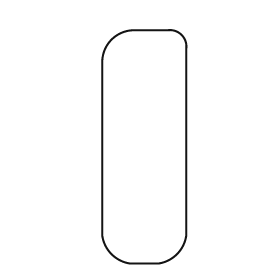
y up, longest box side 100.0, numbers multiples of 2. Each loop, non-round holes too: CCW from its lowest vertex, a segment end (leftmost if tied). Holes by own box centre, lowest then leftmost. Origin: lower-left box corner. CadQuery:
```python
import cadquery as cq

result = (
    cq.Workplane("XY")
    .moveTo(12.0, 0.0)
    .lineTo(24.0, 0.0)
    .threePointArc((32.0, 4.0), (36.0, 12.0))
    .lineTo(36.0, 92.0)
    .threePointArc((34.0, 98.0), (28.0, 100.0))
    .lineTo(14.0, 100.0)
    .threePointArc((4.0, 96.0), (0.0, 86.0))
    .lineTo(0.0, 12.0)
    .threePointArc((4.0, 4.0), (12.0, 0.0))
    .close()
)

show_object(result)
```